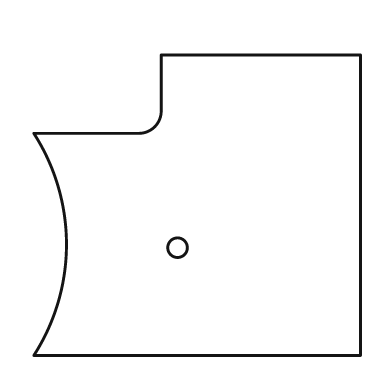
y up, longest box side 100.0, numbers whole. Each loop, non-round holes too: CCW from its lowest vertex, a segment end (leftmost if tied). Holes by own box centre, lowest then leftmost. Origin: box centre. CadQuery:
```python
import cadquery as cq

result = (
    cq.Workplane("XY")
    .moveTo(-50.0, -46.0)
    .lineTo(50.0, -46.0)
    .lineTo(50.0, 46.0)
    .lineTo(-11.0, 46.0)
    .lineTo(-11.0, 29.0)
    .threePointArc((-13.0, 24.0), (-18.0, 22.0))
    .lineTo(-50.0, 22.0)
    .threePointArc((-40.0, -12.0), (-50.0, -46.0))
    .close()
    .moveTo(-6.0, -13.0)
    .circle(3.0)
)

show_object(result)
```